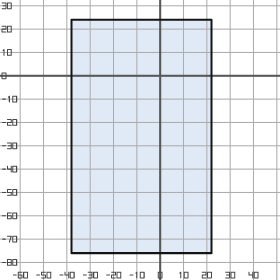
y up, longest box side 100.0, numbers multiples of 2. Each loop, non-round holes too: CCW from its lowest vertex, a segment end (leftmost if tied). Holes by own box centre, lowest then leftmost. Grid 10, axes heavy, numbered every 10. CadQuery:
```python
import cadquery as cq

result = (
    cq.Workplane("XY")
    .moveTo(-38.0, -76.0)
    .lineTo(22.0, -76.0)
    .lineTo(22.0, 24.0)
    .lineTo(-38.0, 24.0)
    .close()
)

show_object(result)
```